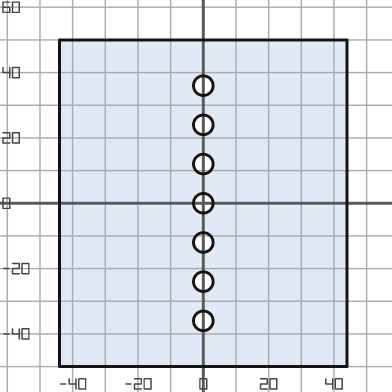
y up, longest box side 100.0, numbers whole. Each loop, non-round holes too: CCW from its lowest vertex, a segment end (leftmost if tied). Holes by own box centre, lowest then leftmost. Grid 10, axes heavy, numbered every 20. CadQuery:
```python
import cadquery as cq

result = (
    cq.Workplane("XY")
    .moveTo(-44.0, -50.0)
    .lineTo(44.0, -50.0)
    .lineTo(44.0, 50.0)
    .lineTo(-44.0, 50.0)
    .close()
    .moveTo(0.0, -36.0)
    .circle(3.0)
    .moveTo(0.0, -24.0)
    .circle(3.0)
    .moveTo(0.0, -12.0)
    .circle(3.0)
    .moveTo(0.0, 0.0)
    .circle(3.0)
    .moveTo(0.0, 12.0)
    .circle(3.0)
    .moveTo(0.0, 24.0)
    .circle(3.0)
    .moveTo(0.0, 36.0)
    .circle(3.0)
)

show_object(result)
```